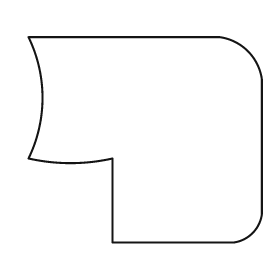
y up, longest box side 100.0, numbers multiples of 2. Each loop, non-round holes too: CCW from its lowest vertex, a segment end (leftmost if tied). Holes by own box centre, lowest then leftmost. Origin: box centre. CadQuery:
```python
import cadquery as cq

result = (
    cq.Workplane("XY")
    .moveTo(-14.0, -44.0)
    .lineTo(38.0, -44.0)
    .threePointArc((46.0, -40.0), (50.0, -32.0))
    .lineTo(50.0, 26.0)
    .threePointArc((44.0, 38.0), (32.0, 44.0))
    .lineTo(-50.0, 44.0)
    .threePointArc((-44.0, 18.0), (-50.0, -8.0))
    .threePointArc((-32.0, -10.0), (-14.0, -8.0))
    .close()
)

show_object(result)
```